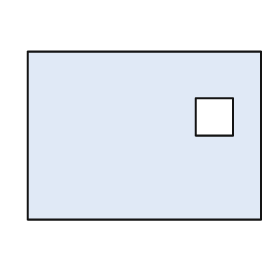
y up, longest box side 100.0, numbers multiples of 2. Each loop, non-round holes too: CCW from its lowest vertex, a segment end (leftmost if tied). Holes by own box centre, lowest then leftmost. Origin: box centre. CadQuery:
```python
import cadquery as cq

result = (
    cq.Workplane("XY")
    .moveTo(-50.0, -36.0)
    .lineTo(50.0, -36.0)
    .lineTo(50.0, 36.0)
    .lineTo(-50.0, 36.0)
    .close()
    .moveTo(22.0, 0.0)
    .lineTo(38.0, 0.0)
    .lineTo(38.0, 16.0)
    .lineTo(22.0, 16.0)
    .close()
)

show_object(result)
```